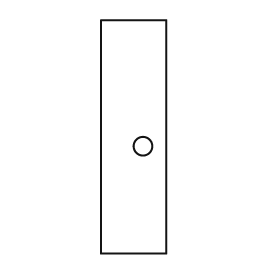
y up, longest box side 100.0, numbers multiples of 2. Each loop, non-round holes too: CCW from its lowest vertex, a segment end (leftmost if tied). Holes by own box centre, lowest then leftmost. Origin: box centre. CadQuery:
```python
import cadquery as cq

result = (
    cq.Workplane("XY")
    .moveTo(-14.0, -50.0)
    .lineTo(14.0, -50.0)
    .lineTo(14.0, 50.0)
    .lineTo(-14.0, 50.0)
    .close()
    .moveTo(4.0, -4.0)
    .circle(4.0)
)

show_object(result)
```